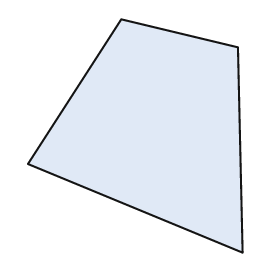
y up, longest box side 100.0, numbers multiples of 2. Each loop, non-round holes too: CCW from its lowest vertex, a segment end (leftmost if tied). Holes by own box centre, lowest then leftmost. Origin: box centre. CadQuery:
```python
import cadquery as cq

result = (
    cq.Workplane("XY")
    .moveTo(46.0, -50.0)
    .lineTo(44.0, 38.0)
    .lineTo(-6.0, 50.0)
    .lineTo(-46.0, -12.0)
    .close()
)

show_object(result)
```